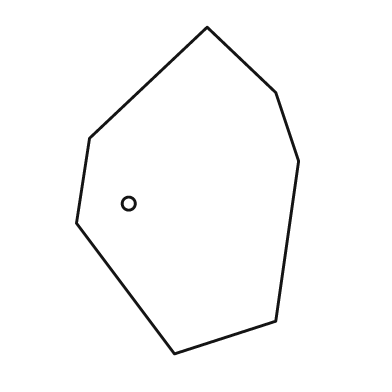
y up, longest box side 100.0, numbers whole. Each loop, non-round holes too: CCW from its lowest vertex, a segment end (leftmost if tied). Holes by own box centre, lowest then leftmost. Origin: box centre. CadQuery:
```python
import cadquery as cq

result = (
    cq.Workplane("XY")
    .moveTo(-4.0, -50.0)
    .lineTo(27.0, -40.0)
    .lineTo(34.0, 9.0)
    .lineTo(27.0, 30.0)
    .lineTo(6.0, 50.0)
    .lineTo(-30.0, 16.0)
    .lineTo(-34.0, -10.0)
    .close()
    .moveTo(-18.0, -4.0)
    .circle(2.0)
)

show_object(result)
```